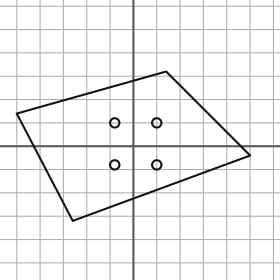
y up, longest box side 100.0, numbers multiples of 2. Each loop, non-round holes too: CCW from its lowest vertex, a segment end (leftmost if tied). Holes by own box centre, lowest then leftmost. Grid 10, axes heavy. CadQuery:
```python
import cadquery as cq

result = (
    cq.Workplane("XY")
    .moveTo(-26.0, -32.0)
    .lineTo(50.0, -4.0)
    .lineTo(14.0, 32.0)
    .lineTo(-50.0, 14.0)
    .close()
    .moveTo(-8.0, -8.0)
    .circle(2.0)
    .moveTo(10.0, -8.0)
    .circle(2.0)
    .moveTo(-8.0, 10.0)
    .circle(2.0)
    .moveTo(10.0, 10.0)
    .circle(2.0)
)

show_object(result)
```